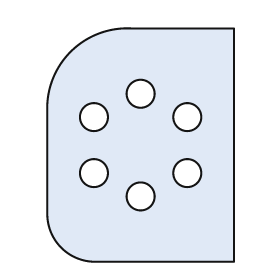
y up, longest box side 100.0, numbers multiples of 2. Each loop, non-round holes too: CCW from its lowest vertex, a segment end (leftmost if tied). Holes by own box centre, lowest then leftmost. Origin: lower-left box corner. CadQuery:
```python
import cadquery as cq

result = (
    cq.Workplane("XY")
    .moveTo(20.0, 0.0)
    .lineTo(80.0, 0.0)
    .lineTo(80.0, 100.0)
    .lineTo(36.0, 100.0)
    .threePointArc((10.0, 90.0), (0.0, 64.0))
    .lineTo(0.0, 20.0)
    .threePointArc((6.0, 6.0), (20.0, 0.0))
    .close()
    .moveTo(40.0, 28.0)
    .circle(6.0)
    .moveTo(20.0, 38.0)
    .circle(6.0)
    .moveTo(60.0, 38.0)
    .circle(6.0)
    .moveTo(20.0, 62.0)
    .circle(6.0)
    .moveTo(60.0, 62.0)
    .circle(6.0)
    .moveTo(40.0, 72.0)
    .circle(6.0)
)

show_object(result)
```